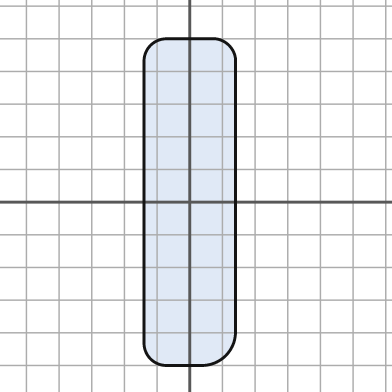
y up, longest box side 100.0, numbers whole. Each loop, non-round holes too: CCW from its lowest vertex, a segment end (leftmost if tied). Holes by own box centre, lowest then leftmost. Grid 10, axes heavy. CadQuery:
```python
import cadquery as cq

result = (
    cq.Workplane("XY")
    .moveTo(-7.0, -50.0)
    .lineTo(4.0, -50.0)
    .threePointArc((11.0, -47.0), (14.0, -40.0))
    .lineTo(14.0, 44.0)
    .threePointArc((12.0, 48.0), (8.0, 50.0))
    .lineTo(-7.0, 50.0)
    .threePointArc((-12.0, 48.0), (-14.0, 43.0))
    .lineTo(-14.0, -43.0)
    .threePointArc((-12.0, -48.0), (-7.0, -50.0))
    .close()
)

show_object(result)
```